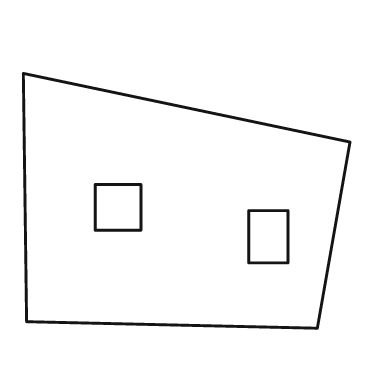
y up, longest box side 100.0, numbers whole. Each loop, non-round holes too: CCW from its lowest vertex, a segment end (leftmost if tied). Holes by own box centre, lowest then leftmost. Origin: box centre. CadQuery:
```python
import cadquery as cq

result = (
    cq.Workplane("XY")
    .moveTo(40.0, -39.0)
    .lineTo(50.0, 18.0)
    .lineTo(-50.0, 39.0)
    .lineTo(-49.0, -37.0)
    .close()
    .moveTo(19.0, -19.0)
    .lineTo(31.0, -19.0)
    .lineTo(31.0, -3.0)
    .lineTo(19.0, -3.0)
    .close()
    .moveTo(-28.0, -9.0)
    .lineTo(-14.0, -9.0)
    .lineTo(-14.0, 5.0)
    .lineTo(-28.0, 5.0)
    .close()
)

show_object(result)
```